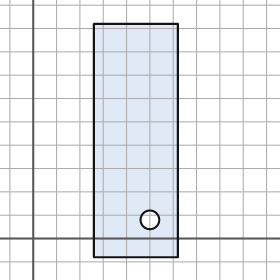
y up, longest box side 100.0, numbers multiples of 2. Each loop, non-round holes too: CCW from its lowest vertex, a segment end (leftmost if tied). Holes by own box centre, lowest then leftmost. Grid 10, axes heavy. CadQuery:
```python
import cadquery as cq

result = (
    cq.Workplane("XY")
    .moveTo(26.0, -8.0)
    .lineTo(62.0, -8.0)
    .lineTo(62.0, 92.0)
    .lineTo(26.0, 92.0)
    .close()
    .moveTo(50.0, 8.0)
    .circle(4.0)
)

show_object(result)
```